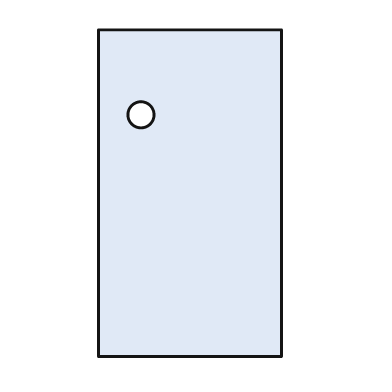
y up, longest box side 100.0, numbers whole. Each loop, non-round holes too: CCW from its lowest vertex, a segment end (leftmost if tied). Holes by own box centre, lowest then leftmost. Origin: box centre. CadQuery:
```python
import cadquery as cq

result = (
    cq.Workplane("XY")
    .moveTo(-28.0, -50.0)
    .lineTo(28.0, -50.0)
    .lineTo(28.0, 50.0)
    .lineTo(-28.0, 50.0)
    .close()
    .moveTo(-15.0, 24.0)
    .circle(4.0)
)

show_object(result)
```